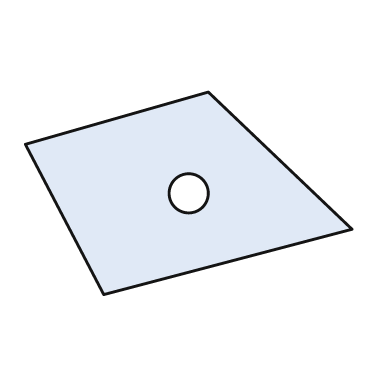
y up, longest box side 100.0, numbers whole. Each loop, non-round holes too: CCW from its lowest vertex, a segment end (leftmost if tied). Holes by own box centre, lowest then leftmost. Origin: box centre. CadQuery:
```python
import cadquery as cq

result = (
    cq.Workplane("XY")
    .moveTo(-26.0, -31.0)
    .lineTo(50.0, -11.0)
    .lineTo(6.0, 31.0)
    .lineTo(-50.0, 15.0)
    .close()
    .moveTo(0.0, 0.0)
    .circle(6.0)
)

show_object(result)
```